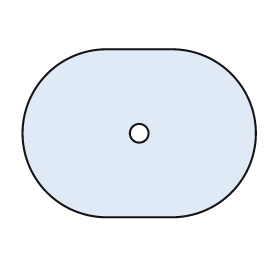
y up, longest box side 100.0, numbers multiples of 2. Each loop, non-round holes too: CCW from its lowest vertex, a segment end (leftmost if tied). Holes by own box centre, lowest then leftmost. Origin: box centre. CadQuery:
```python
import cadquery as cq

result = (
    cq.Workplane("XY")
    .moveTo(-14.0, -36.0)
    .lineTo(14.0, -36.0)
    .threePointArc((50.0, 0.0), (14.0, 36.0))
    .lineTo(-14.0, 36.0)
    .threePointArc((-50.0, 0.0), (-14.0, -36.0))
    .close()
    .moveTo(0.0, 0.0)
    .circle(4.0)
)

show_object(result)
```